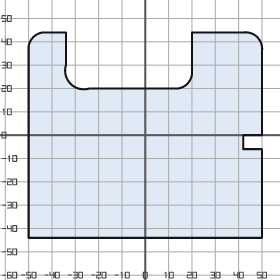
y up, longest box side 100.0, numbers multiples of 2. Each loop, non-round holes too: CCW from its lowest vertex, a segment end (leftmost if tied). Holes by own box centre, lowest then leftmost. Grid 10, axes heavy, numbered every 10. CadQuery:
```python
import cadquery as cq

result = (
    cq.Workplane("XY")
    .moveTo(-50.0, -44.0)
    .lineTo(50.0, -44.0)
    .lineTo(50.0, -6.0)
    .lineTo(42.0, -6.0)
    .lineTo(42.0, 0.0)
    .lineTo(50.0, 0.0)
    .lineTo(50.0, 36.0)
    .threePointArc((48.0, 42.0), (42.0, 44.0))
    .lineTo(20.0, 44.0)
    .lineTo(20.0, 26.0)
    .threePointArc((18.0, 22.0), (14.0, 20.0))
    .lineTo(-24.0, 20.0)
    .threePointArc((-32.0, 22.0), (-34.0, 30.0))
    .lineTo(-34.0, 44.0)
    .lineTo(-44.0, 44.0)
    .threePointArc((-48.0, 42.0), (-50.0, 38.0))
    .close()
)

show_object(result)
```